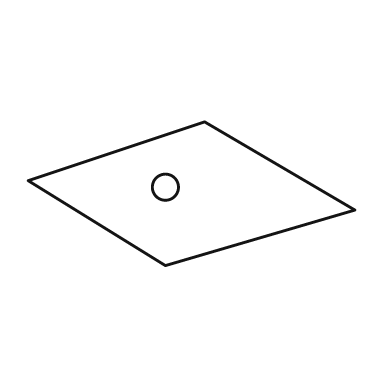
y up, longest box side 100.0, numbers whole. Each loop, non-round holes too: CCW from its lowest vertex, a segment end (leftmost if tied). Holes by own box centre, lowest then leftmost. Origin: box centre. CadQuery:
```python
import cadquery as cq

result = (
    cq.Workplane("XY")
    .moveTo(-8.0, -22.0)
    .lineTo(50.0, -5.0)
    .lineTo(4.0, 22.0)
    .lineTo(-50.0, 4.0)
    .close()
    .moveTo(-8.0, 2.0)
    .circle(4.0)
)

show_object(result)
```